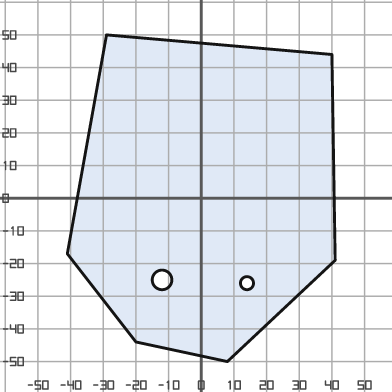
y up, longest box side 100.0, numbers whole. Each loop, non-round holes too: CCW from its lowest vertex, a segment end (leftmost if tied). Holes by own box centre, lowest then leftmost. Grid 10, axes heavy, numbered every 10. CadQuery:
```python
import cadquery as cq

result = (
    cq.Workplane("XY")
    .moveTo(8.0, -50.0)
    .lineTo(41.0, -19.0)
    .lineTo(40.0, 44.0)
    .lineTo(-29.0, 50.0)
    .lineTo(-41.0, -17.0)
    .lineTo(-20.0, -44.0)
    .close()
    .moveTo(14.0, -26.0)
    .circle(2.0)
    .moveTo(-12.0, -25.0)
    .circle(3.0)
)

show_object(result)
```